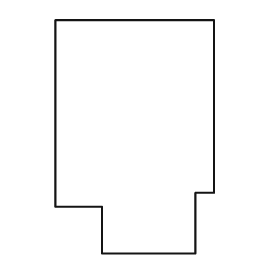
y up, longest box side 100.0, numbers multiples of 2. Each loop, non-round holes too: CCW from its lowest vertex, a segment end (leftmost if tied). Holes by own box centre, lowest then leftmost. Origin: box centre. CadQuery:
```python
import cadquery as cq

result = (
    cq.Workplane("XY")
    .moveTo(-14.0, -50.0)
    .lineTo(26.0, -50.0)
    .lineTo(26.0, -24.0)
    .lineTo(34.0, -24.0)
    .lineTo(34.0, 50.0)
    .lineTo(-34.0, 50.0)
    .lineTo(-34.0, -30.0)
    .lineTo(-14.0, -30.0)
    .close()
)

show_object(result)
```